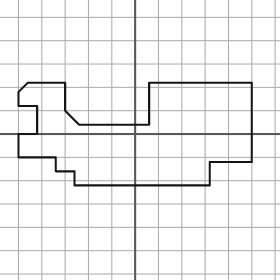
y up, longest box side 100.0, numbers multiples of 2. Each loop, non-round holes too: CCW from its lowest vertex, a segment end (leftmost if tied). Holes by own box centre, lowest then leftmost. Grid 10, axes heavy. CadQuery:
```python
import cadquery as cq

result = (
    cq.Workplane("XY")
    .moveTo(-26.0, -22.0)
    .lineTo(32.0, -22.0)
    .lineTo(32.0, -12.0)
    .lineTo(50.0, -12.0)
    .lineTo(50.0, 22.0)
    .lineTo(6.0, 22.0)
    .lineTo(6.0, 4.0)
    .lineTo(-24.0, 4.0)
    .lineTo(-30.0, 10.0)
    .lineTo(-30.0, 22.0)
    .lineTo(-46.0, 22.0)
    .lineTo(-50.0, 18.0)
    .lineTo(-50.0, 12.0)
    .lineTo(-42.0, 12.0)
    .lineTo(-42.0, 0.0)
    .lineTo(-50.0, 0.0)
    .lineTo(-50.0, -10.0)
    .lineTo(-34.0, -10.0)
    .lineTo(-34.0, -16.0)
    .lineTo(-26.0, -16.0)
    .close()
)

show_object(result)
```